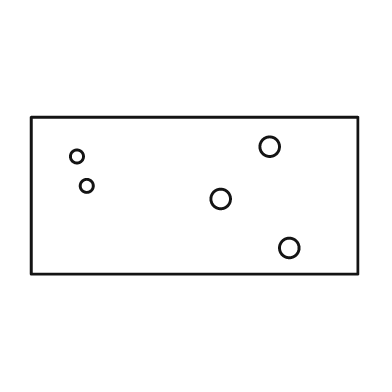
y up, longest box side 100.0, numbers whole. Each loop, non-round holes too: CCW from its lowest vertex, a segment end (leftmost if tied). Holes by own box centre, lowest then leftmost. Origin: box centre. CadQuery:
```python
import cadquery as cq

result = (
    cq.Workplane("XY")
    .moveTo(-50.0, -24.0)
    .lineTo(50.0, -24.0)
    .lineTo(50.0, 24.0)
    .lineTo(-50.0, 24.0)
    .close()
    .moveTo(29.0, -16.0)
    .circle(3.0)
    .moveTo(8.0, -1.0)
    .circle(3.0)
    .moveTo(-33.0, 3.0)
    .circle(2.0)
    .moveTo(-36.0, 12.0)
    .circle(2.0)
    .moveTo(23.0, 15.0)
    .circle(3.0)
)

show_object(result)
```